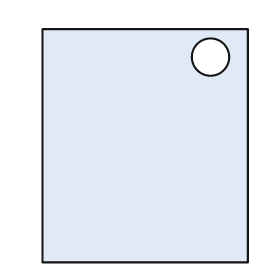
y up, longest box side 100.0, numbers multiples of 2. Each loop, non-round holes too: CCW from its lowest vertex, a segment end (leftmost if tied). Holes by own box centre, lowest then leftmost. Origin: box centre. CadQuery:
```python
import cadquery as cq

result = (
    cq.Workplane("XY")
    .moveTo(-44.0, -50.0)
    .lineTo(44.0, -50.0)
    .lineTo(44.0, 50.0)
    .lineTo(-44.0, 50.0)
    .close()
    .moveTo(28.0, 38.0)
    .circle(8.0)
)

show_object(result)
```